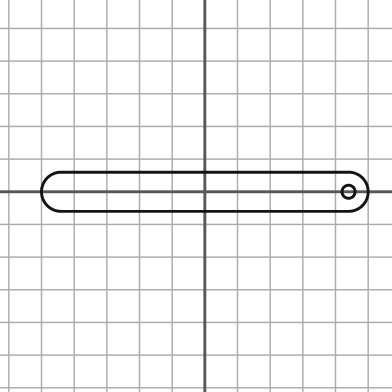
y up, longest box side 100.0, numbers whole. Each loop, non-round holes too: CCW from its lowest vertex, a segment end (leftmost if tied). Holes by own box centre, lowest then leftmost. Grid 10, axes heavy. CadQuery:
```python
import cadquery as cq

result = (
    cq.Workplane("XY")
    .moveTo(-44.0, -6.0)
    .lineTo(44.0, -6.0)
    .threePointArc((50.0, 0.0), (44.0, 6.0))
    .lineTo(-44.0, 6.0)
    .threePointArc((-50.0, 0.0), (-44.0, -6.0))
    .close()
    .moveTo(44.0, 0.0)
    .circle(2.0)
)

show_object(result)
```